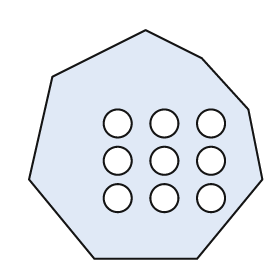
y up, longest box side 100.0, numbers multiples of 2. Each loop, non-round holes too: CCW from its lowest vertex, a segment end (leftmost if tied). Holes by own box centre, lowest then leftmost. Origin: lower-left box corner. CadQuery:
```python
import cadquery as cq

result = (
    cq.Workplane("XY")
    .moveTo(28.0, 0.0)
    .lineTo(72.0, 0.0)
    .lineTo(100.0, 34.0)
    .lineTo(94.0, 64.0)
    .lineTo(74.0, 86.0)
    .lineTo(50.0, 98.0)
    .lineTo(10.0, 78.0)
    .lineTo(0.0, 34.0)
    .close()
    .moveTo(38.0, 26.0)
    .circle(6.0)
    .moveTo(58.0, 26.0)
    .circle(6.0)
    .moveTo(78.0, 26.0)
    .circle(6.0)
    .moveTo(38.0, 42.0)
    .circle(6.0)
    .moveTo(58.0, 42.0)
    .circle(6.0)
    .moveTo(78.0, 42.0)
    .circle(6.0)
    .moveTo(38.0, 58.0)
    .circle(6.0)
    .moveTo(58.0, 58.0)
    .circle(6.0)
    .moveTo(78.0, 58.0)
    .circle(6.0)
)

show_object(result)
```